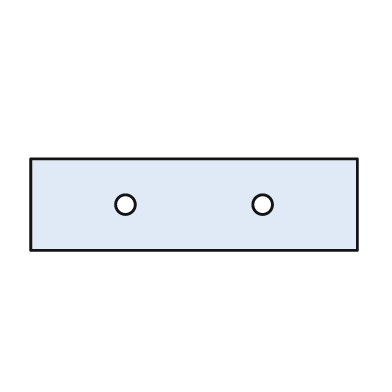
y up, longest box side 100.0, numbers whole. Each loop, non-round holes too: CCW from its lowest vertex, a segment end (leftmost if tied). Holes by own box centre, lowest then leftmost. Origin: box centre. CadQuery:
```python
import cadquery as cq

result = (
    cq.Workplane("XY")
    .moveTo(-50.0, -14.0)
    .lineTo(50.0, -14.0)
    .lineTo(50.0, 14.0)
    .lineTo(-50.0, 14.0)
    .close()
    .moveTo(-21.0, 0.0)
    .circle(3.0)
    .moveTo(21.0, 0.0)
    .circle(3.0)
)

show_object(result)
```